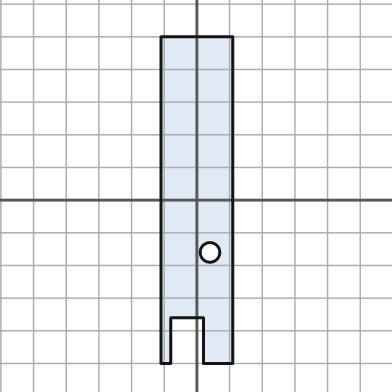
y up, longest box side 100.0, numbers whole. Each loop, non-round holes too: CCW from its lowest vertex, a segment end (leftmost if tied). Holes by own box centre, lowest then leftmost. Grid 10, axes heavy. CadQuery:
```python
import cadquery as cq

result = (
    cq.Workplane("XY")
    .moveTo(-11.0, -50.0)
    .lineTo(-8.0, -50.0)
    .lineTo(-8.0, -36.0)
    .lineTo(2.0, -36.0)
    .lineTo(2.0, -50.0)
    .lineTo(11.0, -50.0)
    .lineTo(11.0, 50.0)
    .lineTo(-11.0, 50.0)
    .close()
    .moveTo(4.0, -16.0)
    .circle(3.0)
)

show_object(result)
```